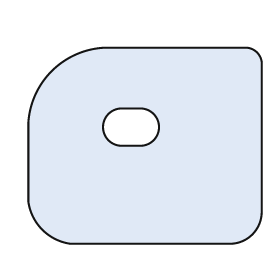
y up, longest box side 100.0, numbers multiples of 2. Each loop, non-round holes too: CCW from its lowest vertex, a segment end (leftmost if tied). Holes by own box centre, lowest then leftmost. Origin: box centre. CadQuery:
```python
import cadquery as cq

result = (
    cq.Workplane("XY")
    .moveTo(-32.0, -42.0)
    .lineTo(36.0, -42.0)
    .threePointArc((46.0, -38.0), (50.0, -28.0))
    .lineTo(50.0, 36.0)
    .threePointArc((48.0, 40.0), (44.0, 42.0))
    .lineTo(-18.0, 42.0)
    .threePointArc((-40.0, 32.0), (-50.0, 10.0))
    .lineTo(-50.0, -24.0)
    .threePointArc((-44.0, -36.0), (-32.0, -42.0))
    .close()
    .moveTo(-10.0, 0.0)
    .lineTo(-2.0, 0.0)
    .threePointArc((6.0, 8.0), (-2.0, 16.0))
    .lineTo(-10.0, 16.0)
    .threePointArc((-18.0, 8.0), (-10.0, 0.0))
    .close()
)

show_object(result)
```